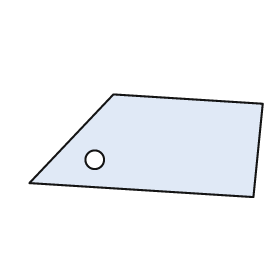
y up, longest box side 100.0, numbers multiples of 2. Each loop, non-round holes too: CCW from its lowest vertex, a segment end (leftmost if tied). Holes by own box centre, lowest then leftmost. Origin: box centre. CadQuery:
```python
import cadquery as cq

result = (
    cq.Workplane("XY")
    .moveTo(46.0, -22.0)
    .lineTo(50.0, 18.0)
    .lineTo(-14.0, 22.0)
    .lineTo(-50.0, -16.0)
    .close()
    .moveTo(-22.0, -6.0)
    .circle(4.0)
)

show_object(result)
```